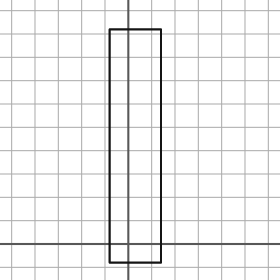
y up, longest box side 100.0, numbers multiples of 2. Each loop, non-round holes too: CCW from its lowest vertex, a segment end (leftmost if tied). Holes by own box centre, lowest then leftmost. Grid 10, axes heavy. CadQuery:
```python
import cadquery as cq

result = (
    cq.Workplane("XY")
    .moveTo(-8.0, -8.0)
    .lineTo(14.0, -8.0)
    .lineTo(14.0, 92.0)
    .lineTo(-8.0, 92.0)
    .close()
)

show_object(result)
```